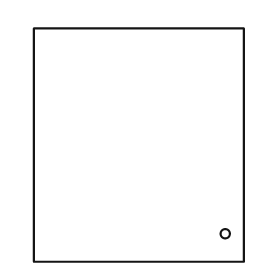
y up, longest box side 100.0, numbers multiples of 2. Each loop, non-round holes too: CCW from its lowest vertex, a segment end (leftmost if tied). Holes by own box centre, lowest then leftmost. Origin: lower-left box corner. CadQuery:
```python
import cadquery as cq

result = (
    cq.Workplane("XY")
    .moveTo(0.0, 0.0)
    .lineTo(90.0, 0.0)
    .lineTo(90.0, 100.0)
    .lineTo(0.0, 100.0)
    .close()
    .moveTo(82.0, 12.0)
    .circle(2.0)
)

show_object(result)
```